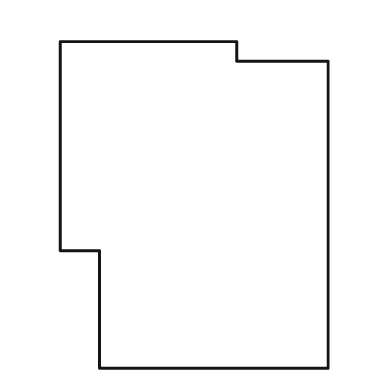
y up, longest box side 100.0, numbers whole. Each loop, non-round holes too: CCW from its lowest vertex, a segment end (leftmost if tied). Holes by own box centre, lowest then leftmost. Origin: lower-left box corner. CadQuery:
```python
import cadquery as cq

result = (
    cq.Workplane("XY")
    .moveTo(12.0, 0.0)
    .lineTo(82.0, 0.0)
    .lineTo(82.0, 94.0)
    .lineTo(54.0, 94.0)
    .lineTo(54.0, 100.0)
    .lineTo(0.0, 100.0)
    .lineTo(0.0, 36.0)
    .lineTo(12.0, 36.0)
    .close()
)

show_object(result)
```